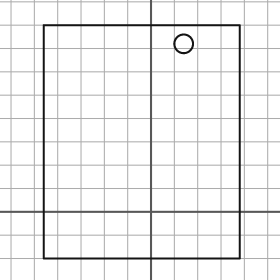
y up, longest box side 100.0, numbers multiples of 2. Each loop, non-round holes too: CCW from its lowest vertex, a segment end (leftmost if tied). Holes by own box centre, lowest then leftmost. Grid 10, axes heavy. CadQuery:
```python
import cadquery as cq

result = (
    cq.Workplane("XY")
    .moveTo(-46.0, -20.0)
    .lineTo(38.0, -20.0)
    .lineTo(38.0, 80.0)
    .lineTo(-46.0, 80.0)
    .close()
    .moveTo(14.0, 72.0)
    .circle(4.0)
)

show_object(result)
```